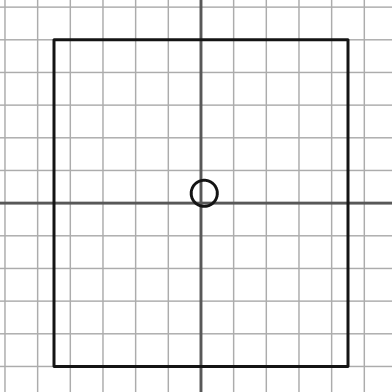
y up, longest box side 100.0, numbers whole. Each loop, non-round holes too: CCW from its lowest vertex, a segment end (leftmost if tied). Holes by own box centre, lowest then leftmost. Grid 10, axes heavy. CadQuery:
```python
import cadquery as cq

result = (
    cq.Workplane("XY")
    .moveTo(-45.0, -50.0)
    .lineTo(45.0, -50.0)
    .lineTo(45.0, 50.0)
    .lineTo(-45.0, 50.0)
    .close()
    .moveTo(1.0, 3.0)
    .circle(4.0)
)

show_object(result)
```